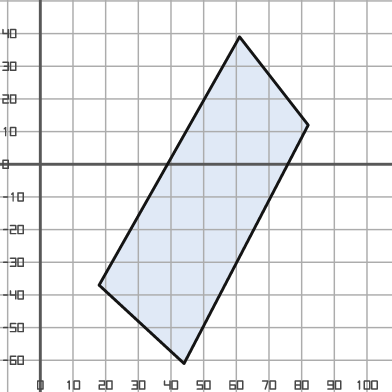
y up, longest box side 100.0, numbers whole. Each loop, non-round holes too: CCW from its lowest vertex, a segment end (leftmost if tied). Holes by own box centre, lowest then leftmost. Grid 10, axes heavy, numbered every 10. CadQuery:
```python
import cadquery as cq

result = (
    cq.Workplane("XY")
    .moveTo(44.0, -61.0)
    .lineTo(82.0, 12.0)
    .lineTo(61.0, 39.0)
    .lineTo(18.0, -37.0)
    .close()
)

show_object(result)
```